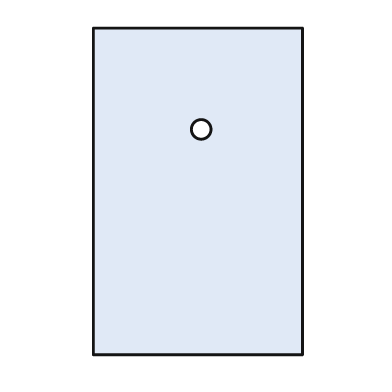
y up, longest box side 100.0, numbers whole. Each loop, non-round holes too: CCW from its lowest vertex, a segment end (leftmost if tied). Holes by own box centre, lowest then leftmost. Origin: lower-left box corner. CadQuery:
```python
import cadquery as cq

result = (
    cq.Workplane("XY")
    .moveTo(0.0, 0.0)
    .lineTo(64.0, 0.0)
    .lineTo(64.0, 100.0)
    .lineTo(0.0, 100.0)
    .close()
    .moveTo(33.0, 69.0)
    .circle(3.0)
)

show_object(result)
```